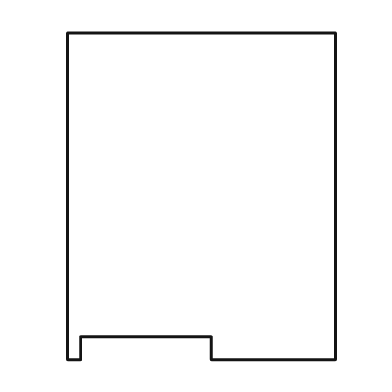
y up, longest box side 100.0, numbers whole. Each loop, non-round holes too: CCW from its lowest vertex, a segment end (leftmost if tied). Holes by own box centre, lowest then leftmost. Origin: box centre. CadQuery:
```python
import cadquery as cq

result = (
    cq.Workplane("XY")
    .moveTo(-41.0, -50.0)
    .lineTo(-37.0, -50.0)
    .lineTo(-37.0, -43.0)
    .lineTo(3.0, -43.0)
    .lineTo(3.0, -50.0)
    .lineTo(41.0, -50.0)
    .lineTo(41.0, 50.0)
    .lineTo(-41.0, 50.0)
    .close()
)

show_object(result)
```